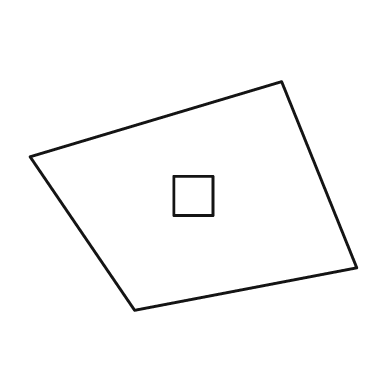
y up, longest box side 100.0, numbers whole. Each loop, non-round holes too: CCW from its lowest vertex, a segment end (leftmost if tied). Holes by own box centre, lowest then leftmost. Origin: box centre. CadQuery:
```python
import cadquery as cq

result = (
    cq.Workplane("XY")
    .moveTo(-18.0, -35.0)
    .lineTo(50.0, -22.0)
    .lineTo(27.0, 35.0)
    .lineTo(-50.0, 12.0)
    .close()
    .moveTo(-6.0, -6.0)
    .lineTo(6.0, -6.0)
    .lineTo(6.0, 6.0)
    .lineTo(-6.0, 6.0)
    .close()
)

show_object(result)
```